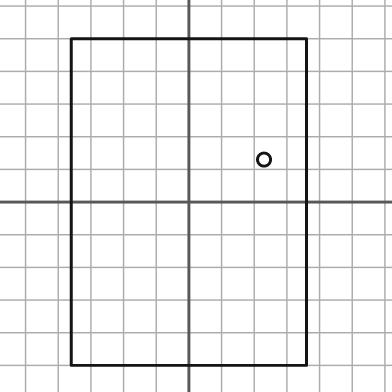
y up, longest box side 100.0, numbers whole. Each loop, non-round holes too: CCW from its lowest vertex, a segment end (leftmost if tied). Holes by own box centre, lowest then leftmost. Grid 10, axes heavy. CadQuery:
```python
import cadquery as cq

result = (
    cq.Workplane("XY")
    .moveTo(-36.0, -50.0)
    .lineTo(36.0, -50.0)
    .lineTo(36.0, 50.0)
    .lineTo(-36.0, 50.0)
    .close()
    .moveTo(23.0, 13.0)
    .circle(2.0)
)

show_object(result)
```